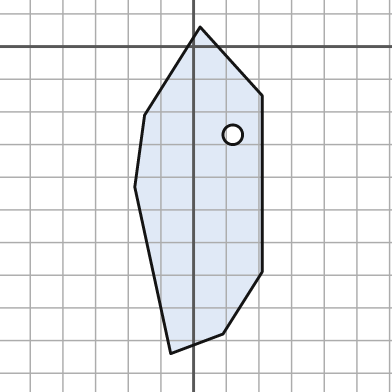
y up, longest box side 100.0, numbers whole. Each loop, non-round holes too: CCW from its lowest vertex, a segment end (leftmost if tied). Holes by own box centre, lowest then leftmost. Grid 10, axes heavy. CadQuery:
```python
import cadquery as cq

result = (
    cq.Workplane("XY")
    .moveTo(-7.0, -94.0)
    .lineTo(9.0, -88.0)
    .lineTo(21.0, -69.0)
    .lineTo(21.0, -15.0)
    .lineTo(2.0, 6.0)
    .lineTo(-15.0, -21.0)
    .lineTo(-18.0, -43.0)
    .close()
    .moveTo(12.0, -27.0)
    .circle(3.0)
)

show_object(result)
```